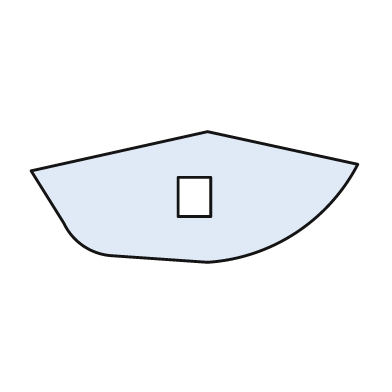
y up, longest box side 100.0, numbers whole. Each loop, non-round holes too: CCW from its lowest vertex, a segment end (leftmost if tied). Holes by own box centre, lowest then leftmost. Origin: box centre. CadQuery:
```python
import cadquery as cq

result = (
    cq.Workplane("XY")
    .moveTo(4.0, -20.0)
    .threePointArc((31.0, -11.0), (50.0, 10.0))
    .lineTo(4.0, 20.0)
    .lineTo(-50.0, 8.0)
    .lineTo(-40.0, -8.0)
    .threePointArc((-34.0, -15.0), (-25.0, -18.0))
    .close()
    .moveTo(-5.0, -6.0)
    .lineTo(5.0, -6.0)
    .lineTo(5.0, 6.0)
    .lineTo(-5.0, 6.0)
    .close()
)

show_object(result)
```